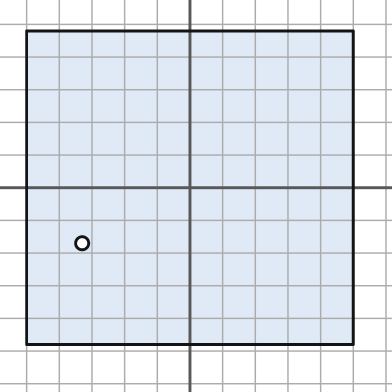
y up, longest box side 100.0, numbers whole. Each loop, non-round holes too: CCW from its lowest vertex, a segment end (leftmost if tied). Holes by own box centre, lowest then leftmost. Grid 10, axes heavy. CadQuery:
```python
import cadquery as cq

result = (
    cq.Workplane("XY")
    .moveTo(-50.0, -48.0)
    .lineTo(50.0, -48.0)
    .lineTo(50.0, 48.0)
    .lineTo(-50.0, 48.0)
    .close()
    .moveTo(-33.0, -17.0)
    .circle(2.0)
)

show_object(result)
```